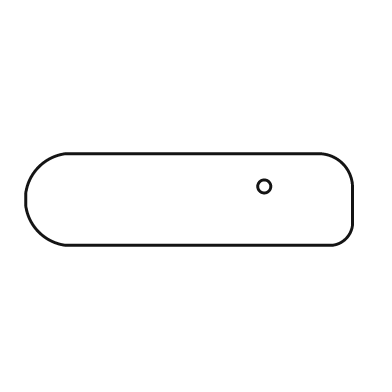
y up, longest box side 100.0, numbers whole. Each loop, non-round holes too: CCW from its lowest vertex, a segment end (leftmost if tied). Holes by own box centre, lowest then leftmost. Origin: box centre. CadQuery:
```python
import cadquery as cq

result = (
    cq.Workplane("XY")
    .moveTo(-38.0, -14.0)
    .lineTo(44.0, -14.0)
    .threePointArc((48.0, -12.0), (50.0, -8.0))
    .lineTo(50.0, 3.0)
    .threePointArc((47.0, 11.0), (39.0, 14.0))
    .lineTo(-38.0, 14.0)
    .threePointArc((-46.0, 10.0), (-50.0, 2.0))
    .lineTo(-50.0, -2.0)
    .threePointArc((-46.0, -10.0), (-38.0, -14.0))
    .close()
    .moveTo(23.0, 4.0)
    .circle(2.0)
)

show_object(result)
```